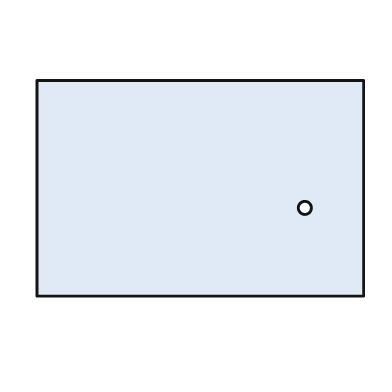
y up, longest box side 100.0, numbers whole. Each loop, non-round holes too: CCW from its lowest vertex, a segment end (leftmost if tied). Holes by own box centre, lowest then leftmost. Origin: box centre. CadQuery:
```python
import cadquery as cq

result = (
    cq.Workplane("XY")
    .moveTo(-50.0, -33.0)
    .lineTo(50.0, -33.0)
    .lineTo(50.0, 33.0)
    .lineTo(-50.0, 33.0)
    .close()
    .moveTo(32.0, -6.0)
    .circle(2.0)
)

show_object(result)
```